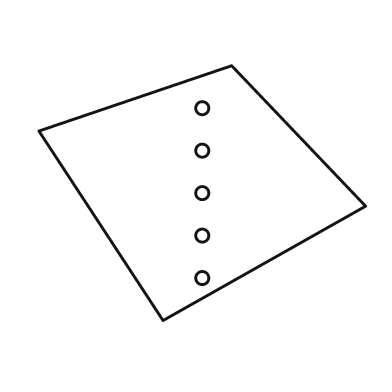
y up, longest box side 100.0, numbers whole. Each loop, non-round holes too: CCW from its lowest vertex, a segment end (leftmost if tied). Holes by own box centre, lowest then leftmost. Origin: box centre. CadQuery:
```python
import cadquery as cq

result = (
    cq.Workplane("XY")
    .moveTo(-12.0, -39.0)
    .lineTo(50.0, -4.0)
    .lineTo(9.0, 39.0)
    .lineTo(-50.0, 19.0)
    .close()
    .moveTo(0.0, -26.0)
    .circle(2.0)
    .moveTo(0.0, -13.0)
    .circle(2.0)
    .moveTo(0.0, 0.0)
    .circle(2.0)
    .moveTo(0.0, 13.0)
    .circle(2.0)
    .moveTo(0.0, 26.0)
    .circle(2.0)
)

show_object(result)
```